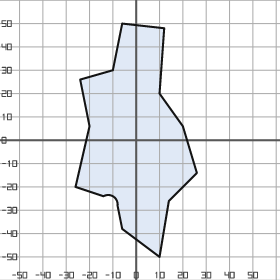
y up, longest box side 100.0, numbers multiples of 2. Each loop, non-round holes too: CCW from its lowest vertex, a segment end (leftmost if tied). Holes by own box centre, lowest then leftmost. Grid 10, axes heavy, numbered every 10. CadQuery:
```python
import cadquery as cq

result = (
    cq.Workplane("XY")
    .moveTo(10.0, -50.0)
    .lineTo(14.0, -26.0)
    .lineTo(26.0, -14.0)
    .lineTo(20.0, 6.0)
    .lineTo(10.0, 20.0)
    .lineTo(12.0, 48.0)
    .lineTo(-6.0, 50.0)
    .lineTo(-10.0, 30.0)
    .lineTo(-24.0, 26.0)
    .lineTo(-20.0, 6.0)
    .lineTo(-26.0, -20.0)
    .lineTo(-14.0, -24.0)
    .threePointArc((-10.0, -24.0), (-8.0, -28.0))
    .lineTo(-6.0, -38.0)
    .close()
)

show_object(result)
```